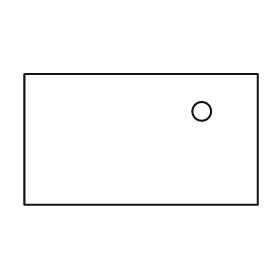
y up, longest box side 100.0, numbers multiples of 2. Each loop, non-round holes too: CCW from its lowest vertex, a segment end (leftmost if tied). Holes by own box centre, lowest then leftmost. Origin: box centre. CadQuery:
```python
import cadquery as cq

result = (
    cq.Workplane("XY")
    .moveTo(-50.0, -28.0)
    .lineTo(50.0, -28.0)
    .lineTo(50.0, 28.0)
    .lineTo(-50.0, 28.0)
    .close()
    .moveTo(26.0, 12.0)
    .circle(4.0)
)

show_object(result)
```